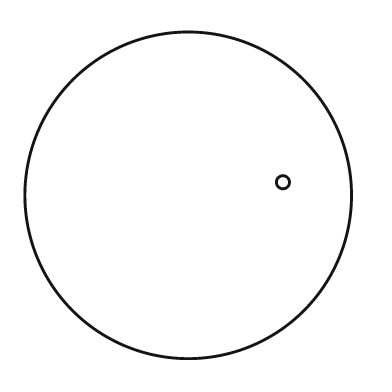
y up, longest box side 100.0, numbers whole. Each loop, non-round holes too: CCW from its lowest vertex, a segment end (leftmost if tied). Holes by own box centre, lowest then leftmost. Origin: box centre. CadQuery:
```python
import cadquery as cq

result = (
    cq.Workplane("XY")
    .moveTo(0.0, 0.0)
    .circle(50.0)
    .moveTo(29.0, 4.0)
    .circle(2.0)
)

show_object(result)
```